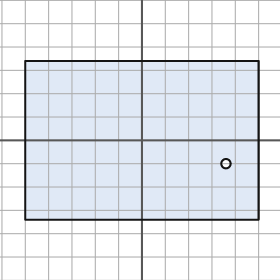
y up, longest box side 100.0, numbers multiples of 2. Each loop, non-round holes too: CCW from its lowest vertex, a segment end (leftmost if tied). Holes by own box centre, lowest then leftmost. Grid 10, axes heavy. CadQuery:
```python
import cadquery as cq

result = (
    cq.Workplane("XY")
    .moveTo(-50.0, -34.0)
    .lineTo(50.0, -34.0)
    .lineTo(50.0, 34.0)
    .lineTo(-50.0, 34.0)
    .close()
    .moveTo(36.0, -10.0)
    .circle(2.0)
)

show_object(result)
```